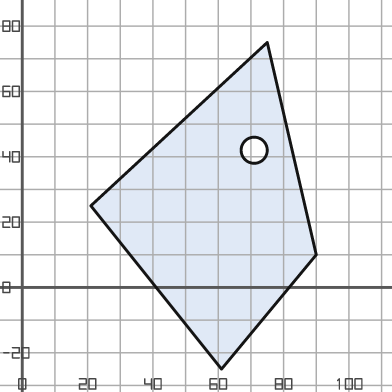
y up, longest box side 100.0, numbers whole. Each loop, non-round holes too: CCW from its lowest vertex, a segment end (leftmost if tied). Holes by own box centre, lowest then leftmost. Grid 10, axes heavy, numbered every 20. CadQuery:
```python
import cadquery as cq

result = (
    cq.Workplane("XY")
    .moveTo(61.0, -25.0)
    .lineTo(90.0, 10.0)
    .lineTo(75.0, 75.0)
    .lineTo(21.0, 25.0)
    .close()
    .moveTo(71.0, 42.0)
    .circle(4.0)
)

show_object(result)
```